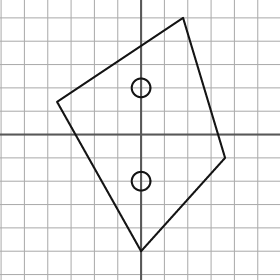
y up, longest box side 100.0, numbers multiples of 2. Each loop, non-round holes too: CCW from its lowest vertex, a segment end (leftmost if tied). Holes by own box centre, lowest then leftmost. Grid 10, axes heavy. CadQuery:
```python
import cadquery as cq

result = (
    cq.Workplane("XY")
    .moveTo(0.0, -50.0)
    .lineTo(36.0, -10.0)
    .lineTo(18.0, 50.0)
    .lineTo(-36.0, 14.0)
    .close()
    .moveTo(0.0, -20.0)
    .circle(4.0)
    .moveTo(0.0, 20.0)
    .circle(4.0)
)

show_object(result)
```